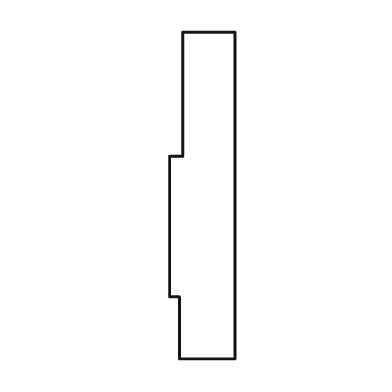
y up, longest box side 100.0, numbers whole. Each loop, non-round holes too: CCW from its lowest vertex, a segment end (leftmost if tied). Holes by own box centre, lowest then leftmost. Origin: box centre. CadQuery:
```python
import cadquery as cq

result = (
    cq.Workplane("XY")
    .moveTo(-7.0, -50.0)
    .lineTo(10.0, -50.0)
    .lineTo(10.0, 50.0)
    .lineTo(-6.0, 50.0)
    .lineTo(-6.0, 12.0)
    .lineTo(-10.0, 12.0)
    .lineTo(-10.0, -31.0)
    .lineTo(-7.0, -31.0)
    .close()
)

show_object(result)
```